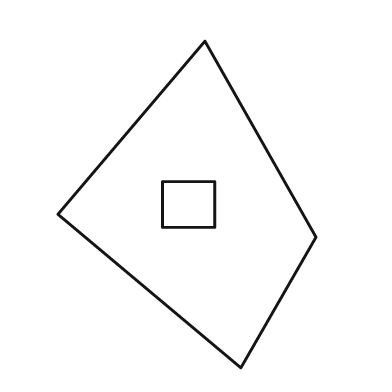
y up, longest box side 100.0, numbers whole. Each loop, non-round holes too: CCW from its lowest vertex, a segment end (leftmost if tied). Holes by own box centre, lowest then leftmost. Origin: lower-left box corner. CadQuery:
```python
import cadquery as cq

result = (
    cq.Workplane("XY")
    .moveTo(56.0, 0.0)
    .lineTo(79.0, 40.0)
    .lineTo(45.0, 100.0)
    .lineTo(0.0, 47.0)
    .close()
    .moveTo(32.0, 43.0)
    .lineTo(48.0, 43.0)
    .lineTo(48.0, 57.0)
    .lineTo(32.0, 57.0)
    .close()
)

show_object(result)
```